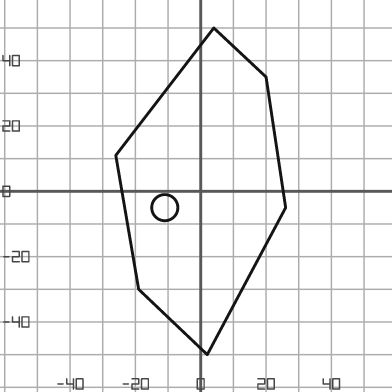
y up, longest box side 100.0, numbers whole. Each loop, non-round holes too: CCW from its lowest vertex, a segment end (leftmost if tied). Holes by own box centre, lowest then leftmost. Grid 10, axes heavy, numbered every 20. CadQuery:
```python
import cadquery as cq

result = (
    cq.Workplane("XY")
    .moveTo(2.0, -50.0)
    .lineTo(26.0, -5.0)
    .lineTo(20.0, 35.0)
    .lineTo(4.0, 50.0)
    .lineTo(-26.0, 11.0)
    .lineTo(-19.0, -30.0)
    .close()
    .moveTo(-11.0, -5.0)
    .circle(4.0)
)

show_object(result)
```